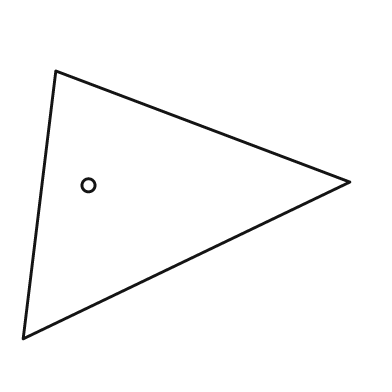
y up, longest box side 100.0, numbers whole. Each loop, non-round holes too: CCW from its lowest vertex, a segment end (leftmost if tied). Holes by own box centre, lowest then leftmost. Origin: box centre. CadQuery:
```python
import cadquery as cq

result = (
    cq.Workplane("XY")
    .moveTo(-50.0, -41.0)
    .lineTo(50.0, 7.0)
    .lineTo(-40.0, 41.0)
    .close()
    .moveTo(-30.0, 6.0)
    .circle(2.0)
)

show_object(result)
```